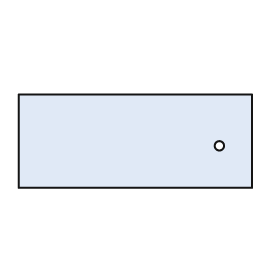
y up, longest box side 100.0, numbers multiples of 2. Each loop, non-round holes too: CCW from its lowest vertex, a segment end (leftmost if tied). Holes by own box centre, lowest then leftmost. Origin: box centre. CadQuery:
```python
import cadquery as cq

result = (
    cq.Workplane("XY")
    .moveTo(-50.0, -20.0)
    .lineTo(50.0, -20.0)
    .lineTo(50.0, 20.0)
    .lineTo(-50.0, 20.0)
    .close()
    .moveTo(36.0, -2.0)
    .circle(2.0)
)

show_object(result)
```